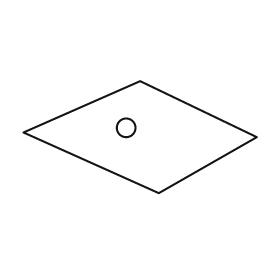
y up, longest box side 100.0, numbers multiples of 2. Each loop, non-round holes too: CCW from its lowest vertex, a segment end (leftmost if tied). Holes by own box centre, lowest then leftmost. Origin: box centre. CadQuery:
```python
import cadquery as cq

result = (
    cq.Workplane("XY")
    .moveTo(8.0, -24.0)
    .lineTo(50.0, 0.0)
    .lineTo(0.0, 24.0)
    .lineTo(-50.0, 2.0)
    .close()
    .moveTo(-6.0, 4.0)
    .circle(4.0)
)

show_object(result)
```